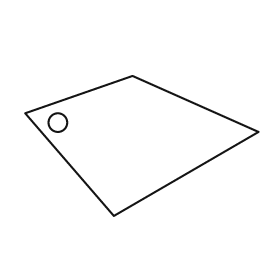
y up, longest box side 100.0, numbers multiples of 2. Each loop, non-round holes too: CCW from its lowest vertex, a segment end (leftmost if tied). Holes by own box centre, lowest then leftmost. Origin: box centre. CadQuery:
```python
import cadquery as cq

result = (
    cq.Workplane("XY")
    .moveTo(-12.0, -30.0)
    .lineTo(50.0, 6.0)
    .lineTo(-4.0, 30.0)
    .lineTo(-50.0, 14.0)
    .close()
    .moveTo(-36.0, 10.0)
    .circle(4.0)
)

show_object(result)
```